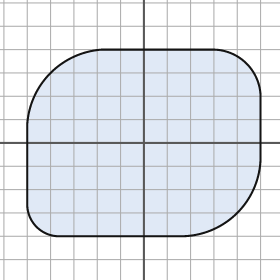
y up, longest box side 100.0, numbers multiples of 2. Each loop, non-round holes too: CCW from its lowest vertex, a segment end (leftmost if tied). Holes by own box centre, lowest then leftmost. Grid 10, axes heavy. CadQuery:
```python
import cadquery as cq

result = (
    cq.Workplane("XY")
    .moveTo(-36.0, -40.0)
    .lineTo(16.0, -40.0)
    .threePointArc((40.0, -30.0), (50.0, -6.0))
    .lineTo(50.0, 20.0)
    .threePointArc((44.0, 34.0), (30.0, 40.0))
    .lineTo(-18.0, 40.0)
    .threePointArc((-40.0, 30.0), (-50.0, 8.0))
    .lineTo(-50.0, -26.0)
    .threePointArc((-46.0, -36.0), (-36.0, -40.0))
    .close()
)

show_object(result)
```